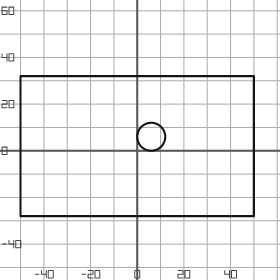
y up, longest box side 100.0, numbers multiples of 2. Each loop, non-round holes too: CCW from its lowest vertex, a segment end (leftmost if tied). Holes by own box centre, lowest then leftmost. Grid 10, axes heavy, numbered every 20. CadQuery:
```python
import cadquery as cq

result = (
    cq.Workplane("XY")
    .moveTo(-50.0, -28.0)
    .lineTo(50.0, -28.0)
    .lineTo(50.0, 32.0)
    .lineTo(-50.0, 32.0)
    .close()
    .moveTo(6.0, 6.0)
    .circle(6.0)
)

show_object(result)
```